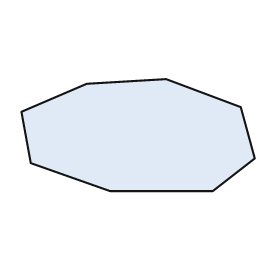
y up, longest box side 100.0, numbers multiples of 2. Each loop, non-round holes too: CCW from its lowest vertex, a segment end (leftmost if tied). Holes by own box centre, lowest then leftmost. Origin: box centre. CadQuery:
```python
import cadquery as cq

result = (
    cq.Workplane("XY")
    .moveTo(-12.0, -24.0)
    .lineTo(32.0, -24.0)
    .lineTo(50.0, -10.0)
    .lineTo(44.0, 12.0)
    .lineTo(12.0, 24.0)
    .lineTo(-22.0, 22.0)
    .lineTo(-50.0, 10.0)
    .lineTo(-46.0, -12.0)
    .close()
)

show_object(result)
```